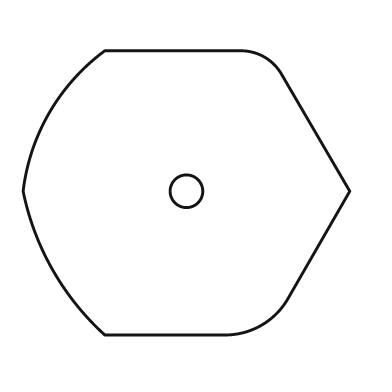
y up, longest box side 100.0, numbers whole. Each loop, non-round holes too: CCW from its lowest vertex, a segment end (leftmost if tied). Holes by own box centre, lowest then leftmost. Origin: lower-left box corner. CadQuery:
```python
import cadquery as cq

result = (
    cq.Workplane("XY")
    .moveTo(25.0, 0.0)
    .lineTo(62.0, 0.0)
    .threePointArc((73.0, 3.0), (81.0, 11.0))
    .lineTo(100.0, 44.0)
    .lineTo(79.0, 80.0)
    .threePointArc((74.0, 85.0), (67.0, 87.0))
    .lineTo(25.0, 87.0)
    .threePointArc((8.0, 68.0), (0.0, 44.0))
    .threePointArc((9.0, 20.0), (25.0, 0.0))
    .close()
    .moveTo(50.0, 44.0)
    .circle(5.0)
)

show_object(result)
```